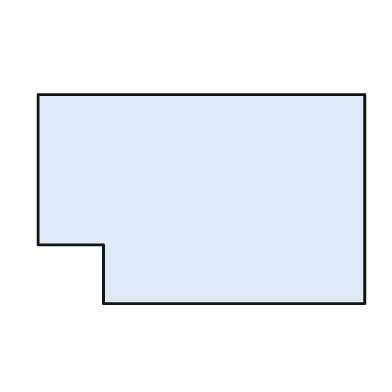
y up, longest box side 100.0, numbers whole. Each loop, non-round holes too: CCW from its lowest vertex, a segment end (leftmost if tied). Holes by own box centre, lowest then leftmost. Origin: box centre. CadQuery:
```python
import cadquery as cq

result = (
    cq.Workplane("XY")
    .moveTo(-30.0, -32.0)
    .lineTo(50.0, -32.0)
    .lineTo(50.0, 32.0)
    .lineTo(-50.0, 32.0)
    .lineTo(-50.0, -14.0)
    .lineTo(-30.0, -14.0)
    .close()
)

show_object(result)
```